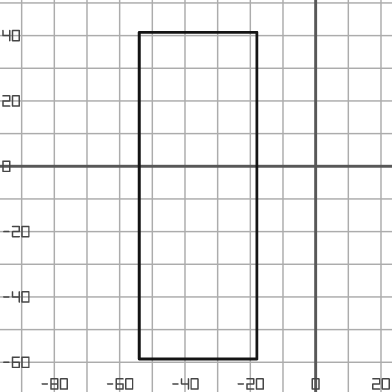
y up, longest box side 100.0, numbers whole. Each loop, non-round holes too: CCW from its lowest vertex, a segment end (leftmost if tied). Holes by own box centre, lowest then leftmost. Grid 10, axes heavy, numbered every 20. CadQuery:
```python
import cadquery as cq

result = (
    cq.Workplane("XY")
    .moveTo(-54.0, -59.0)
    .lineTo(-18.0, -59.0)
    .lineTo(-18.0, 41.0)
    .lineTo(-54.0, 41.0)
    .close()
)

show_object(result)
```